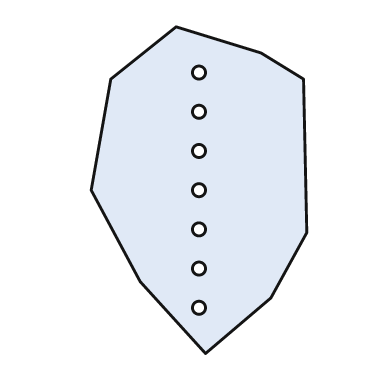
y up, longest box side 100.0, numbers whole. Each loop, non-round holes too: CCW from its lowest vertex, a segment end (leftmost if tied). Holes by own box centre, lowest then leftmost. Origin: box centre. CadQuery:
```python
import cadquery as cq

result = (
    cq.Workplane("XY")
    .moveTo(2.0, -50.0)
    .lineTo(22.0, -33.0)
    .lineTo(33.0, -13.0)
    .lineTo(32.0, 34.0)
    .lineTo(19.0, 42.0)
    .lineTo(-7.0, 50.0)
    .lineTo(-27.0, 34.0)
    .lineTo(-33.0, 0.0)
    .lineTo(-18.0, -28.0)
    .close()
    .moveTo(0.0, -36.0)
    .circle(2.0)
    .moveTo(0.0, -24.0)
    .circle(2.0)
    .moveTo(0.0, -12.0)
    .circle(2.0)
    .moveTo(0.0, 0.0)
    .circle(2.0)
    .moveTo(0.0, 12.0)
    .circle(2.0)
    .moveTo(0.0, 24.0)
    .circle(2.0)
    .moveTo(0.0, 36.0)
    .circle(2.0)
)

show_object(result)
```